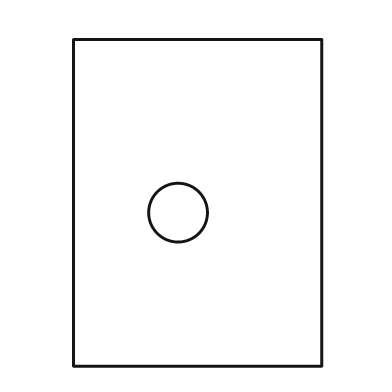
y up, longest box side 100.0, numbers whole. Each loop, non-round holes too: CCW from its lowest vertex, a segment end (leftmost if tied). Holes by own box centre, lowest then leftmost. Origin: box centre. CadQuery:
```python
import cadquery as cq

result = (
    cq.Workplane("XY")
    .moveTo(-38.0, -50.0)
    .lineTo(38.0, -50.0)
    .lineTo(38.0, 50.0)
    .lineTo(-38.0, 50.0)
    .close()
    .moveTo(-6.0, -3.0)
    .circle(9.0)
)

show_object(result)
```